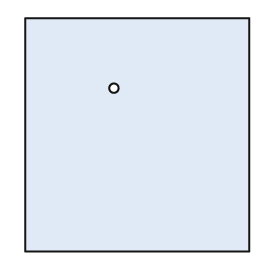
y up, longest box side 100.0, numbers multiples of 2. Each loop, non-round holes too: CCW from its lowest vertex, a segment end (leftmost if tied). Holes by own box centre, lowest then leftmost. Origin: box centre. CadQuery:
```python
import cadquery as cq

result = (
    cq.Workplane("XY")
    .moveTo(-48.0, -50.0)
    .lineTo(48.0, -50.0)
    .lineTo(48.0, 50.0)
    .lineTo(-48.0, 50.0)
    .close()
    .moveTo(-10.0, 20.0)
    .circle(2.0)
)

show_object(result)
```